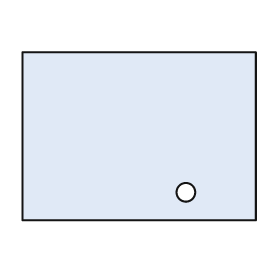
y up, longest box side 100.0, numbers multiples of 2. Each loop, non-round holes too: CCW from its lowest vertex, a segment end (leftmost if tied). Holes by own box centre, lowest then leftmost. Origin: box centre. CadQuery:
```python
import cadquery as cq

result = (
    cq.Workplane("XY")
    .moveTo(-50.0, -36.0)
    .lineTo(50.0, -36.0)
    .lineTo(50.0, 36.0)
    .lineTo(-50.0, 36.0)
    .close()
    .moveTo(20.0, -24.0)
    .circle(4.0)
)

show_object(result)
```